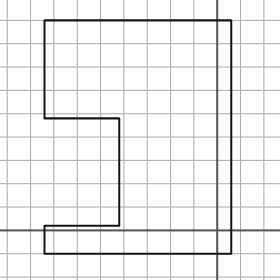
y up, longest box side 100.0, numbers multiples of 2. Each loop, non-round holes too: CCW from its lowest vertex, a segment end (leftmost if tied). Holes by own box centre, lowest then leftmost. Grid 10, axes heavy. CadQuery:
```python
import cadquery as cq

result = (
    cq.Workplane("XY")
    .moveTo(-74.0, -10.0)
    .lineTo(6.0, -10.0)
    .lineTo(6.0, 90.0)
    .lineTo(-74.0, 90.0)
    .lineTo(-74.0, 48.0)
    .lineTo(-42.0, 48.0)
    .lineTo(-42.0, 2.0)
    .lineTo(-74.0, 2.0)
    .close()
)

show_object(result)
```